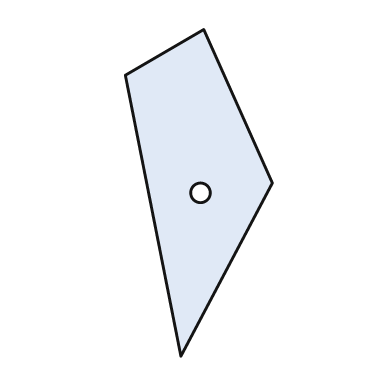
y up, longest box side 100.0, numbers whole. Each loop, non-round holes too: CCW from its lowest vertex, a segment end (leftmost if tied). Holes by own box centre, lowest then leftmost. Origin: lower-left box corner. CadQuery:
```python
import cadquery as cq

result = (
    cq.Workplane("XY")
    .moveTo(17.0, 0.0)
    .lineTo(45.0, 53.0)
    .lineTo(24.0, 100.0)
    .lineTo(0.0, 86.0)
    .close()
    .moveTo(23.0, 50.0)
    .circle(3.0)
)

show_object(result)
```